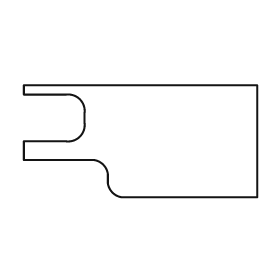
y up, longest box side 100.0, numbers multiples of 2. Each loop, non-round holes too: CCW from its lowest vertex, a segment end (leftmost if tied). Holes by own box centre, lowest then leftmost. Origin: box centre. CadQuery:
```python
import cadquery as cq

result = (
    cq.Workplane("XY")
    .moveTo(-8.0, -24.0)
    .lineTo(50.0, -24.0)
    .lineTo(50.0, 24.0)
    .lineTo(-50.0, 24.0)
    .lineTo(-50.0, 20.0)
    .lineTo(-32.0, 20.0)
    .threePointArc((-26.0, 18.0), (-24.0, 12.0))
    .lineTo(-24.0, 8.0)
    .threePointArc((-26.0, 2.0), (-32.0, 0.0))
    .lineTo(-50.0, 0.0)
    .lineTo(-50.0, -8.0)
    .lineTo(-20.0, -8.0)
    .threePointArc((-16.0, -10.0), (-14.0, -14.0))
    .lineTo(-14.0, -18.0)
    .threePointArc((-12.0, -22.0), (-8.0, -24.0))
    .close()
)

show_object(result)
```